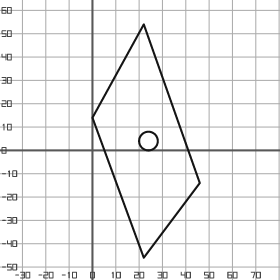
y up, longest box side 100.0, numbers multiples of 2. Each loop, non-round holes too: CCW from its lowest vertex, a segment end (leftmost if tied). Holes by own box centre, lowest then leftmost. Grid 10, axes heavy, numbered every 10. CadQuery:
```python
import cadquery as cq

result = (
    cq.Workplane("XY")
    .moveTo(22.0, -46.0)
    .lineTo(46.0, -14.0)
    .lineTo(22.0, 54.0)
    .lineTo(0.0, 14.0)
    .close()
    .moveTo(24.0, 4.0)
    .circle(4.0)
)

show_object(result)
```